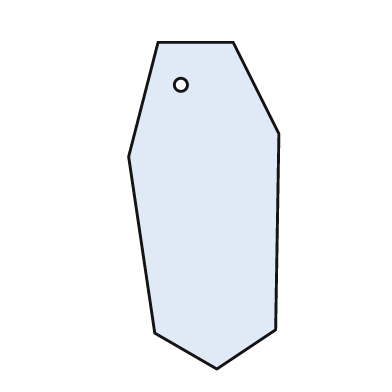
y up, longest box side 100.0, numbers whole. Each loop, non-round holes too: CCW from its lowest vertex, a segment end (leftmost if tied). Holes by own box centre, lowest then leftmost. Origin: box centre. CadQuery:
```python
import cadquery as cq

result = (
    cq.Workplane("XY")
    .moveTo(4.0, -50.0)
    .lineTo(22.0, -38.0)
    .lineTo(23.0, 22.0)
    .lineTo(9.0, 50.0)
    .lineTo(-14.0, 50.0)
    .lineTo(-23.0, 15.0)
    .lineTo(-15.0, -39.0)
    .close()
    .moveTo(-7.0, 37.0)
    .circle(2.0)
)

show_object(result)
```